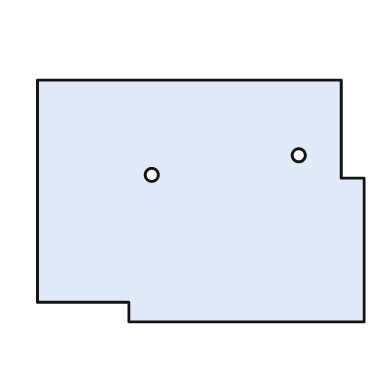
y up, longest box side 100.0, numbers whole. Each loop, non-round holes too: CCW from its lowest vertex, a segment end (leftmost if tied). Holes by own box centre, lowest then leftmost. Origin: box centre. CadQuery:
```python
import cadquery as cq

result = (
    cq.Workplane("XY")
    .moveTo(-22.0, -37.0)
    .lineTo(50.0, -37.0)
    .lineTo(50.0, 7.0)
    .lineTo(43.0, 7.0)
    .lineTo(43.0, 37.0)
    .lineTo(-50.0, 37.0)
    .lineTo(-50.0, -31.0)
    .lineTo(-22.0, -31.0)
    .close()
    .moveTo(-15.0, 8.0)
    .circle(2.0)
    .moveTo(30.0, 14.0)
    .circle(2.0)
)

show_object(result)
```